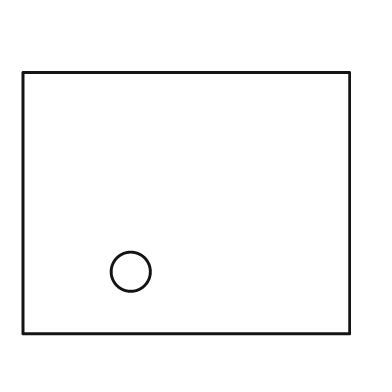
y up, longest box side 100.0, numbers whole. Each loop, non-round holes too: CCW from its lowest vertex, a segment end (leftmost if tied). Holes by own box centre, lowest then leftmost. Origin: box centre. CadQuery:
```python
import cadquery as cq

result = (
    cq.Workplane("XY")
    .moveTo(-50.0, -40.0)
    .lineTo(50.0, -40.0)
    .lineTo(50.0, 40.0)
    .lineTo(-50.0, 40.0)
    .close()
    .moveTo(-17.0, -21.0)
    .circle(6.0)
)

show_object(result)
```